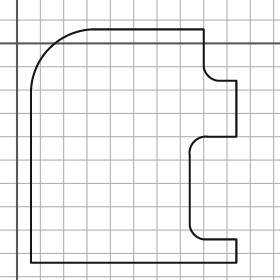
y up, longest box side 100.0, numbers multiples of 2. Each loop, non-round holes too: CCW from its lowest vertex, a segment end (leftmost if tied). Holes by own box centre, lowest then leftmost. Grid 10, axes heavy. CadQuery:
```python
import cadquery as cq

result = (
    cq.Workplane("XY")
    .moveTo(6.0, -94.0)
    .lineTo(94.0, -94.0)
    .lineTo(94.0, -84.0)
    .lineTo(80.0, -84.0)
    .threePointArc((76.0, -82.0), (74.0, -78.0))
    .lineTo(74.0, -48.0)
    .threePointArc((76.0, -42.0), (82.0, -40.0))
    .lineTo(94.0, -40.0)
    .lineTo(94.0, -16.0)
    .lineTo(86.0, -16.0)
    .threePointArc((82.0, -14.0), (80.0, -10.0))
    .lineTo(80.0, 6.0)
    .lineTo(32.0, 6.0)
    .threePointArc((14.0, -2.0), (6.0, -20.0))
    .close()
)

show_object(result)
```